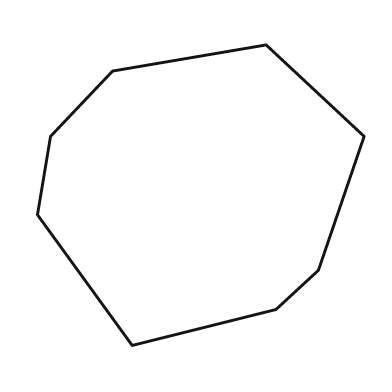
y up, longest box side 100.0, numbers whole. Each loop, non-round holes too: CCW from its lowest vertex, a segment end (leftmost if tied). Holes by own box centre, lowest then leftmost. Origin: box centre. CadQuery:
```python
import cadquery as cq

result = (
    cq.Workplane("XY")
    .moveTo(-21.0, -46.0)
    .lineTo(23.0, -35.0)
    .lineTo(36.0, -23.0)
    .lineTo(50.0, 18.0)
    .lineTo(20.0, 46.0)
    .lineTo(-27.0, 38.0)
    .lineTo(-46.0, 18.0)
    .lineTo(-50.0, -6.0)
    .close()
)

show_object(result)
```